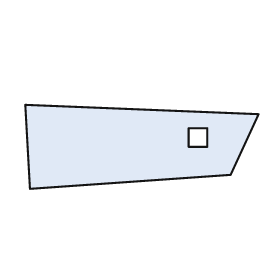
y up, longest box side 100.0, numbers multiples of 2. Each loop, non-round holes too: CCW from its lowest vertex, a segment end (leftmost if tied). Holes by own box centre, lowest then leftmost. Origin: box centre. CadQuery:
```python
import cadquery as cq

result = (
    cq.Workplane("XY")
    .moveTo(-48.0, -18.0)
    .lineTo(38.0, -12.0)
    .lineTo(50.0, 14.0)
    .lineTo(-50.0, 18.0)
    .close()
    .moveTo(20.0, 0.0)
    .lineTo(28.0, 0.0)
    .lineTo(28.0, 8.0)
    .lineTo(20.0, 8.0)
    .close()
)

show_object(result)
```